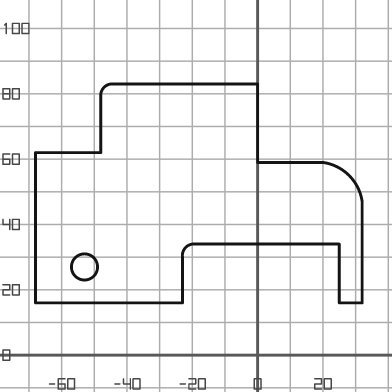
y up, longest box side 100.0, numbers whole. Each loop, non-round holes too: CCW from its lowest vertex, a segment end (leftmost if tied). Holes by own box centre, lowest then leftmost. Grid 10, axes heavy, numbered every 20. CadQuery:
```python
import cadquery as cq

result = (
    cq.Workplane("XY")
    .moveTo(-68.0, 16.0)
    .lineTo(-23.0, 16.0)
    .lineTo(-23.0, 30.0)
    .threePointArc((-22.0, 33.0), (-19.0, 34.0))
    .lineTo(25.0, 34.0)
    .lineTo(25.0, 16.0)
    .lineTo(32.0, 16.0)
    .lineTo(32.0, 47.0)
    .threePointArc((28.0, 55.0), (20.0, 59.0))
    .lineTo(0.0, 59.0)
    .lineTo(0.0, 83.0)
    .lineTo(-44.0, 83.0)
    .threePointArc((-47.0, 82.0), (-48.0, 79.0))
    .lineTo(-48.0, 62.0)
    .lineTo(-68.0, 62.0)
    .close()
    .moveTo(-53.0, 27.0)
    .circle(4.0)
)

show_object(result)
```